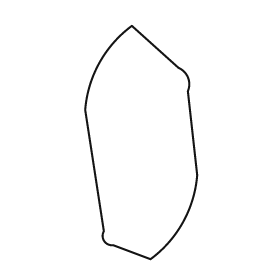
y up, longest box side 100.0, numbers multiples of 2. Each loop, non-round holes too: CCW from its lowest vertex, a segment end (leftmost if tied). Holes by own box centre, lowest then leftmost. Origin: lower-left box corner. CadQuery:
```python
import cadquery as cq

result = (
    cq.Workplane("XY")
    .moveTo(28.0, 0.0)
    .threePointArc((42.0, 16.0), (48.0, 36.0))
    .lineTo(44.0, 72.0)
    .threePointArc((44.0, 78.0), (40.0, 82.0))
    .lineTo(20.0, 100.0)
    .threePointArc((6.0, 84.0), (0.0, 64.0))
    .lineTo(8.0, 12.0)
    .threePointArc((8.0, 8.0), (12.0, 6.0))
    .close()
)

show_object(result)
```